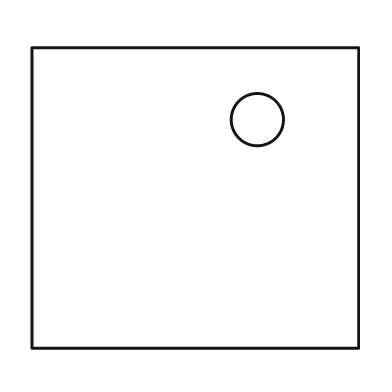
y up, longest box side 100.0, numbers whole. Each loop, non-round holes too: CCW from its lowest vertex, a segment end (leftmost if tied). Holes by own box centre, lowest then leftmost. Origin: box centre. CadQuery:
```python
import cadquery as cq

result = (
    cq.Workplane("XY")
    .moveTo(-50.0, -46.0)
    .lineTo(50.0, -46.0)
    .lineTo(50.0, 46.0)
    .lineTo(-50.0, 46.0)
    .close()
    .moveTo(19.0, 24.0)
    .circle(8.0)
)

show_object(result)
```